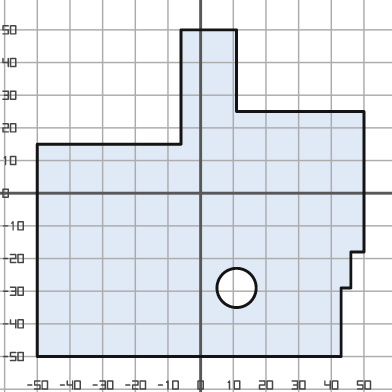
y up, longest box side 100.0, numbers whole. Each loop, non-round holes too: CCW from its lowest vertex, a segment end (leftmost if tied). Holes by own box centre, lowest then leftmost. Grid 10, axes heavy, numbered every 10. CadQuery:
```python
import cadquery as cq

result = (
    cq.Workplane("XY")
    .moveTo(-50.0, -50.0)
    .lineTo(43.0, -50.0)
    .lineTo(43.0, -29.0)
    .lineTo(46.0, -29.0)
    .lineTo(46.0, -18.0)
    .lineTo(50.0, -18.0)
    .lineTo(50.0, 25.0)
    .lineTo(11.0, 25.0)
    .lineTo(11.0, 50.0)
    .lineTo(-6.0, 50.0)
    .lineTo(-6.0, 15.0)
    .lineTo(-50.0, 15.0)
    .close()
    .moveTo(11.0, -29.0)
    .circle(6.0)
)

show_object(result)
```